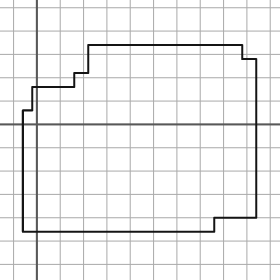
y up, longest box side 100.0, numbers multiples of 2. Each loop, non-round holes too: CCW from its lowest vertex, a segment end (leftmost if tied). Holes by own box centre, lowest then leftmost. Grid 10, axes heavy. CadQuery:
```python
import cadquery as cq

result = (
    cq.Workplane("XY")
    .moveTo(-6.0, -46.0)
    .lineTo(76.0, -46.0)
    .lineTo(76.0, -40.0)
    .lineTo(94.0, -40.0)
    .lineTo(94.0, 28.0)
    .lineTo(88.0, 28.0)
    .lineTo(88.0, 34.0)
    .lineTo(22.0, 34.0)
    .lineTo(22.0, 22.0)
    .lineTo(16.0, 22.0)
    .lineTo(16.0, 16.0)
    .lineTo(-2.0, 16.0)
    .lineTo(-2.0, 6.0)
    .lineTo(-6.0, 6.0)
    .close()
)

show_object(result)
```